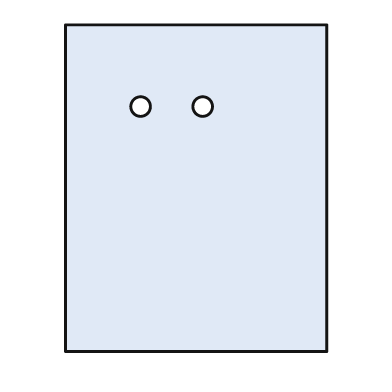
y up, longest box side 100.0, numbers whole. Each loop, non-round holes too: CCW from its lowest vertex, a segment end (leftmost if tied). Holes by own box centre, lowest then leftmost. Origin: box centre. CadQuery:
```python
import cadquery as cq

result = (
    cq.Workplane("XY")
    .moveTo(-40.0, -50.0)
    .lineTo(40.0, -50.0)
    .lineTo(40.0, 50.0)
    .lineTo(-40.0, 50.0)
    .close()
    .moveTo(-17.0, 25.0)
    .circle(3.0)
    .moveTo(2.0, 25.0)
    .circle(3.0)
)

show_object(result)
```